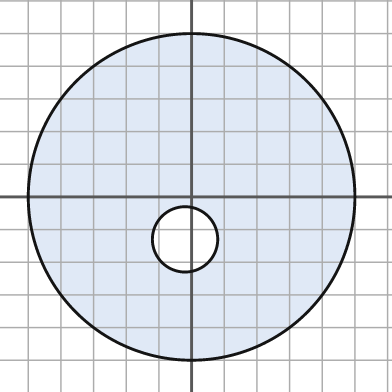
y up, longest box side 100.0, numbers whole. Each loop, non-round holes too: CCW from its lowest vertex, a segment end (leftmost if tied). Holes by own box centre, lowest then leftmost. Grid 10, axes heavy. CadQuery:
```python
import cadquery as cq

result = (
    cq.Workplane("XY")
    .moveTo(0.0, 0.0)
    .circle(50.0)
    .moveTo(-2.0, -13.0)
    .circle(10.0)
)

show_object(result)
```